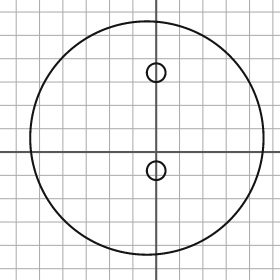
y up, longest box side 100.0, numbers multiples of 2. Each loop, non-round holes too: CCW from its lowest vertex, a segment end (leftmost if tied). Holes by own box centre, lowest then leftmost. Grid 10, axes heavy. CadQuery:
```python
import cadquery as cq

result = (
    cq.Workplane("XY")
    .moveTo(-4.0, 6.0)
    .circle(50.0)
    .moveTo(0.0, -8.0)
    .circle(4.0)
    .moveTo(0.0, 34.0)
    .circle(4.0)
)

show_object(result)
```